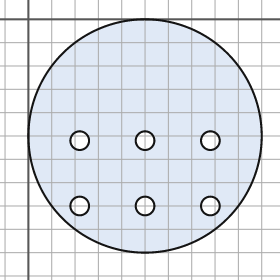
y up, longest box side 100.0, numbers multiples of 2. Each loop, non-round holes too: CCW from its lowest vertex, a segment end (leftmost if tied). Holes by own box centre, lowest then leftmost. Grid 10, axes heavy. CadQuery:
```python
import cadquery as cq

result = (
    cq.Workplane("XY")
    .moveTo(50.0, -50.0)
    .circle(50.0)
    .moveTo(22.0, -80.0)
    .circle(4.0)
    .moveTo(50.0, -80.0)
    .circle(4.0)
    .moveTo(78.0, -80.0)
    .circle(4.0)
    .moveTo(22.0, -52.0)
    .circle(4.0)
    .moveTo(50.0, -52.0)
    .circle(4.0)
    .moveTo(78.0, -52.0)
    .circle(4.0)
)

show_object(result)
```